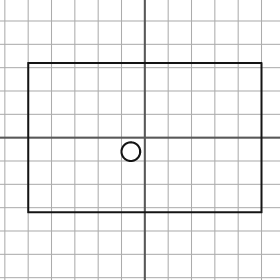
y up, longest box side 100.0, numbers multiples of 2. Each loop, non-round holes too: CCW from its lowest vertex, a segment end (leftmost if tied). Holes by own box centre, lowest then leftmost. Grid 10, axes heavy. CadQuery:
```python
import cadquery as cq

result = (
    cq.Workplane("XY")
    .moveTo(-50.0, -32.0)
    .lineTo(50.0, -32.0)
    .lineTo(50.0, 32.0)
    .lineTo(-50.0, 32.0)
    .close()
    .moveTo(-6.0, -6.0)
    .circle(4.0)
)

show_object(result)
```